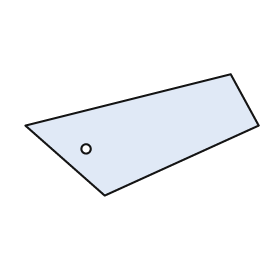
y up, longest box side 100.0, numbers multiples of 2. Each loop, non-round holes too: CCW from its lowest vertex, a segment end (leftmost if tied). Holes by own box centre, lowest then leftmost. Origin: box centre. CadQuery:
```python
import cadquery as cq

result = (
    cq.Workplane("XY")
    .moveTo(-16.0, -26.0)
    .lineTo(50.0, 4.0)
    .lineTo(38.0, 26.0)
    .lineTo(-50.0, 4.0)
    .close()
    .moveTo(-24.0, -6.0)
    .circle(2.0)
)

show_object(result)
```